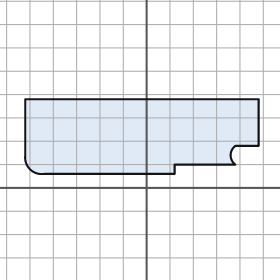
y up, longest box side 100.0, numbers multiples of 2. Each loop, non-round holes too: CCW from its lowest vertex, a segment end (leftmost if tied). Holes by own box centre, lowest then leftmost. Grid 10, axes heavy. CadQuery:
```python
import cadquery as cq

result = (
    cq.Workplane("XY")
    .moveTo(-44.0, 6.0)
    .lineTo(12.0, 6.0)
    .lineTo(12.0, 10.0)
    .lineTo(38.0, 10.0)
    .threePointArc((36.0, 14.0), (38.0, 18.0))
    .lineTo(48.0, 18.0)
    .lineTo(48.0, 38.0)
    .lineTo(-52.0, 38.0)
    .lineTo(-52.0, 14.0)
    .threePointArc((-50.0, 8.0), (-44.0, 6.0))
    .close()
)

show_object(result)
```